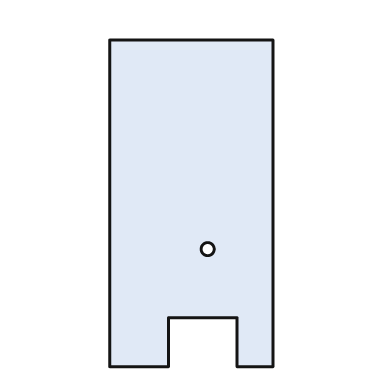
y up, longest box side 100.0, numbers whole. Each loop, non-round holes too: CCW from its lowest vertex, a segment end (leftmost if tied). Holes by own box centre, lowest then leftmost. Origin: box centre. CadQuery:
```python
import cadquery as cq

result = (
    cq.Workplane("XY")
    .moveTo(-25.0, -50.0)
    .lineTo(-7.0, -50.0)
    .lineTo(-7.0, -35.0)
    .lineTo(14.0, -35.0)
    .lineTo(14.0, -50.0)
    .lineTo(25.0, -50.0)
    .lineTo(25.0, 50.0)
    .lineTo(-25.0, 50.0)
    .close()
    .moveTo(5.0, -14.0)
    .circle(2.0)
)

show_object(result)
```